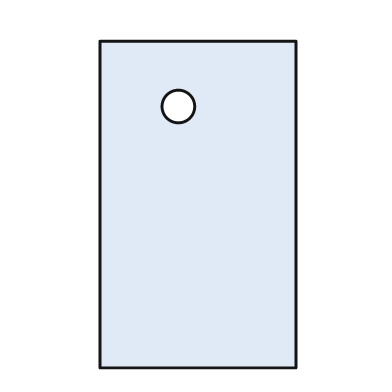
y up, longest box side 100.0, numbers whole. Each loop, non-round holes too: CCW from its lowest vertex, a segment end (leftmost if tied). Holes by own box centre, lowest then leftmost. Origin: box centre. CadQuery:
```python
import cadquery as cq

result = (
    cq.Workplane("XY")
    .moveTo(-30.0, -50.0)
    .lineTo(30.0, -50.0)
    .lineTo(30.0, 50.0)
    .lineTo(-30.0, 50.0)
    .close()
    .moveTo(-6.0, 30.0)
    .circle(5.0)
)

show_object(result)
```